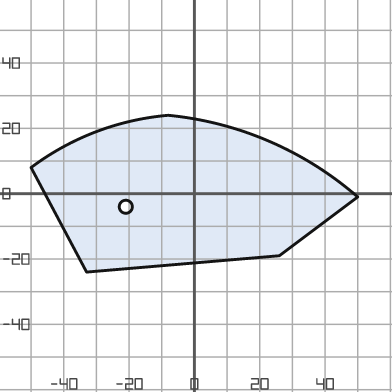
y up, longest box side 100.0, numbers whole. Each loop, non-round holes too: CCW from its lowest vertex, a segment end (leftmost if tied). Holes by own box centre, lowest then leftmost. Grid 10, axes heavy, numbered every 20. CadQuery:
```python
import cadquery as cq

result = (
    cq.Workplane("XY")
    .moveTo(-33.0, -24.0)
    .lineTo(26.0, -19.0)
    .lineTo(50.0, -1.0)
    .threePointArc((23.0, 16.0), (-8.0, 24.0))
    .threePointArc((-30.0, 19.0), (-50.0, 8.0))
    .close()
    .moveTo(-21.0, -4.0)
    .circle(2.0)
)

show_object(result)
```